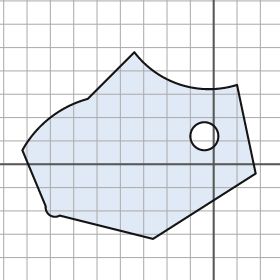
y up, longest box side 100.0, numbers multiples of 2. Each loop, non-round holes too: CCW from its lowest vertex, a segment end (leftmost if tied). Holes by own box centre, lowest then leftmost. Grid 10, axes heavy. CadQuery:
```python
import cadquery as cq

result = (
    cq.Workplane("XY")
    .moveTo(-26.0, -32.0)
    .lineTo(18.0, -4.0)
    .lineTo(10.0, 34.0)
    .threePointArc((-14.0, 34.0), (-34.0, 48.0))
    .lineTo(-54.0, 28.0)
    .threePointArc((-70.0, 20.0), (-82.0, 6.0))
    .lineTo(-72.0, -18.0)
    .threePointArc((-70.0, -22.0), (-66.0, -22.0))
    .close()
    .moveTo(-4.0, 12.0)
    .circle(6.0)
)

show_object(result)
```